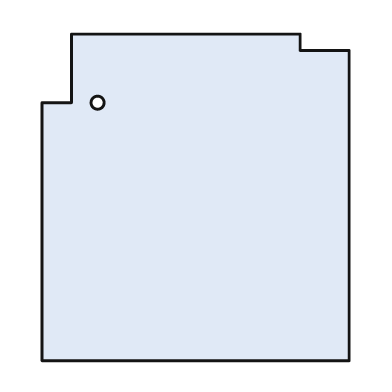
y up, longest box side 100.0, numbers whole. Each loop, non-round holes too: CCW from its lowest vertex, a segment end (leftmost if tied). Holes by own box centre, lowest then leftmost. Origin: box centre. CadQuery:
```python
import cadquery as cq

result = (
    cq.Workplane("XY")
    .moveTo(-47.0, -50.0)
    .lineTo(47.0, -50.0)
    .lineTo(47.0, 45.0)
    .lineTo(32.0, 45.0)
    .lineTo(32.0, 50.0)
    .lineTo(-38.0, 50.0)
    .lineTo(-38.0, 29.0)
    .lineTo(-47.0, 29.0)
    .close()
    .moveTo(-30.0, 29.0)
    .circle(2.0)
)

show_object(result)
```